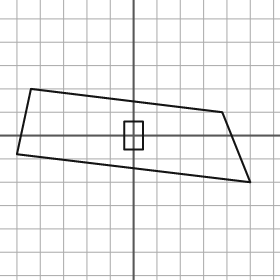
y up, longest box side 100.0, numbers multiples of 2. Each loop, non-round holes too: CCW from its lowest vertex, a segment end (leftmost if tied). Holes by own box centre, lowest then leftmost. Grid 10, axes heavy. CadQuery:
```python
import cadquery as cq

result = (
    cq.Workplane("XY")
    .moveTo(50.0, -20.0)
    .lineTo(38.0, 10.0)
    .lineTo(-44.0, 20.0)
    .lineTo(-50.0, -8.0)
    .close()
    .moveTo(-4.0, -6.0)
    .lineTo(4.0, -6.0)
    .lineTo(4.0, 6.0)
    .lineTo(-4.0, 6.0)
    .close()
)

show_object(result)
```